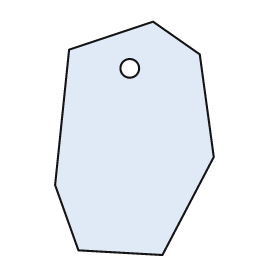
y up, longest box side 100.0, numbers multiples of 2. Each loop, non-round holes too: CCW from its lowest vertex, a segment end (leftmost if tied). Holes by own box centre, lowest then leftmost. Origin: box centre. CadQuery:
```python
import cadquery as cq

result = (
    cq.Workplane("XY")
    .moveTo(12.0, -50.0)
    .lineTo(34.0, -8.0)
    .lineTo(28.0, 36.0)
    .lineTo(8.0, 50.0)
    .lineTo(-28.0, 38.0)
    .lineTo(-34.0, -20.0)
    .lineTo(-24.0, -48.0)
    .close()
    .moveTo(-2.0, 30.0)
    .circle(4.0)
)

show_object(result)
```